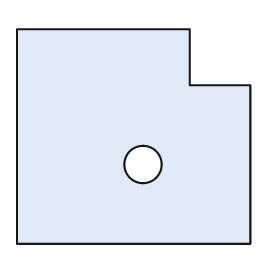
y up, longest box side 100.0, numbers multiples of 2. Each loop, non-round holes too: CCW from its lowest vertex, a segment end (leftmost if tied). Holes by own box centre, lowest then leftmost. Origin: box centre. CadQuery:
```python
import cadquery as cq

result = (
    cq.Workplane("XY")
    .moveTo(-50.0, -46.0)
    .lineTo(50.0, -46.0)
    .lineTo(50.0, 22.0)
    .lineTo(24.0, 22.0)
    .lineTo(24.0, 46.0)
    .lineTo(-50.0, 46.0)
    .close()
    .moveTo(4.0, -12.0)
    .circle(8.0)
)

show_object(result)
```